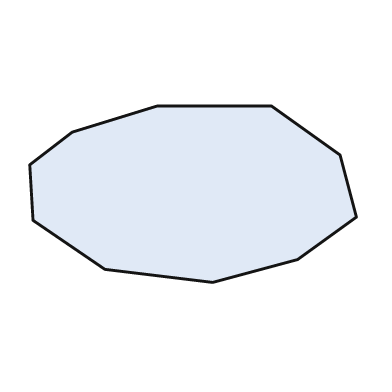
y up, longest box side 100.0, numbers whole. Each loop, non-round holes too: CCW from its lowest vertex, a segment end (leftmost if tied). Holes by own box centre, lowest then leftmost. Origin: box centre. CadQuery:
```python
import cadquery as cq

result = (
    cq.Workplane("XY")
    .moveTo(6.0, -27.0)
    .lineTo(32.0, -20.0)
    .lineTo(50.0, -7.0)
    .lineTo(45.0, 12.0)
    .lineTo(24.0, 27.0)
    .lineTo(-11.0, 27.0)
    .lineTo(-37.0, 19.0)
    .lineTo(-50.0, 9.0)
    .lineTo(-49.0, -8.0)
    .lineTo(-27.0, -23.0)
    .close()
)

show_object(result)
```